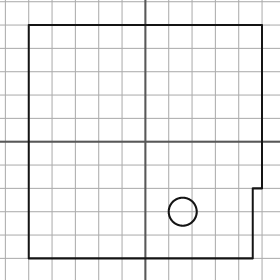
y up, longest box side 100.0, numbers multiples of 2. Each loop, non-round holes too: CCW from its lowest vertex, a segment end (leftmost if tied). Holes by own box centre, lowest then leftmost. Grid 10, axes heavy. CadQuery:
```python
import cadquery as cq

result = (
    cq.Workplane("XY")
    .moveTo(-50.0, -50.0)
    .lineTo(46.0, -50.0)
    .lineTo(46.0, -20.0)
    .lineTo(50.0, -20.0)
    .lineTo(50.0, 50.0)
    .lineTo(-50.0, 50.0)
    .close()
    .moveTo(16.0, -30.0)
    .circle(6.0)
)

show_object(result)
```